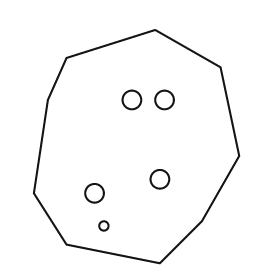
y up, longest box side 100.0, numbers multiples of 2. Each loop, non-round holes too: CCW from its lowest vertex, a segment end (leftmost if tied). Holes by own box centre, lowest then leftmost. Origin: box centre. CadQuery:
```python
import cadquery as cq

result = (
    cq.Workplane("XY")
    .moveTo(10.0, -50.0)
    .lineTo(28.0, -32.0)
    .lineTo(44.0, -4.0)
    .lineTo(36.0, 34.0)
    .lineTo(8.0, 50.0)
    .lineTo(-30.0, 38.0)
    .lineTo(-38.0, 20.0)
    .lineTo(-44.0, -20.0)
    .lineTo(-30.0, -42.0)
    .close()
    .moveTo(-14.0, -34.0)
    .circle(2.0)
    .moveTo(-18.0, -20.0)
    .circle(4.0)
    .moveTo(10.0, -14.0)
    .circle(4.0)
    .moveTo(-2.0, 20.0)
    .circle(4.0)
    .moveTo(12.0, 20.0)
    .circle(4.0)
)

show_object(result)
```